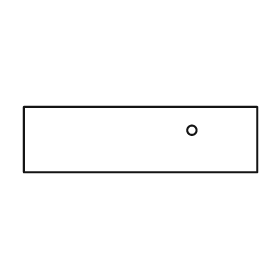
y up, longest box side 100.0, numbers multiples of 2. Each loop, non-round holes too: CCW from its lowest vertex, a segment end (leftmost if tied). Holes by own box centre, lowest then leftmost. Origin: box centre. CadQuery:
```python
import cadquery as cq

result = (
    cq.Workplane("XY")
    .moveTo(-50.0, -14.0)
    .lineTo(50.0, -14.0)
    .lineTo(50.0, 14.0)
    .lineTo(-50.0, 14.0)
    .close()
    .moveTo(22.0, 4.0)
    .circle(2.0)
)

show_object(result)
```